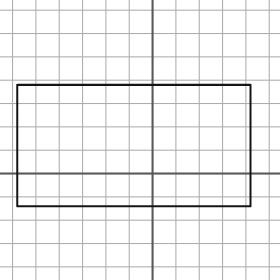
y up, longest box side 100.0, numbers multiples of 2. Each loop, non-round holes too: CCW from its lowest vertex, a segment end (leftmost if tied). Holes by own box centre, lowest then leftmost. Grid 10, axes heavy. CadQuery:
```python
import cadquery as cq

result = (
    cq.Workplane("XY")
    .moveTo(-58.0, -14.0)
    .lineTo(42.0, -14.0)
    .lineTo(42.0, 38.0)
    .lineTo(-58.0, 38.0)
    .close()
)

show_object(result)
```